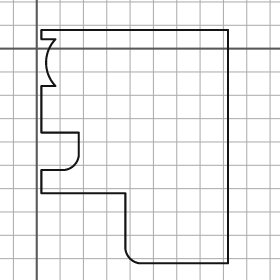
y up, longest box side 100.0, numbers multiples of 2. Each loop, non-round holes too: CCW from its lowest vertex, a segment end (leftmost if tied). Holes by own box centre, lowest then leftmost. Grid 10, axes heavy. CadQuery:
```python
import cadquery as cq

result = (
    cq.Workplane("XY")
    .moveTo(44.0, -92.0)
    .lineTo(82.0, -92.0)
    .lineTo(82.0, 8.0)
    .lineTo(2.0, 8.0)
    .lineTo(2.0, 4.0)
    .lineTo(8.0, 4.0)
    .threePointArc((4.0, -6.0), (8.0, -16.0))
    .lineTo(2.0, -16.0)
    .lineTo(2.0, -36.0)
    .lineTo(18.0, -36.0)
    .lineTo(18.0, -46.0)
    .threePointArc((16.0, -50.0), (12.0, -52.0))
    .lineTo(2.0, -52.0)
    .lineTo(2.0, -62.0)
    .lineTo(38.0, -62.0)
    .lineTo(38.0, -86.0)
    .threePointArc((40.0, -90.0), (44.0, -92.0))
    .close()
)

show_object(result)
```